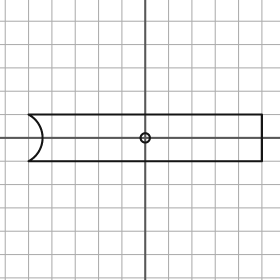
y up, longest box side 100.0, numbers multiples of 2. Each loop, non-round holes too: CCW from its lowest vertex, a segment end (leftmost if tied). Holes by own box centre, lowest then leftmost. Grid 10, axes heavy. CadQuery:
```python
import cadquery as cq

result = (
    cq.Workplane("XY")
    .moveTo(-50.0, -10.0)
    .lineTo(50.0, -10.0)
    .lineTo(50.0, 10.0)
    .lineTo(-50.0, 10.0)
    .threePointArc((-44.0, 0.0), (-50.0, -10.0))
    .close()
    .moveTo(0.0, 0.0)
    .circle(2.0)
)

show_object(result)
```